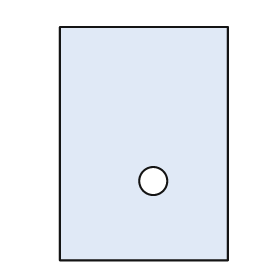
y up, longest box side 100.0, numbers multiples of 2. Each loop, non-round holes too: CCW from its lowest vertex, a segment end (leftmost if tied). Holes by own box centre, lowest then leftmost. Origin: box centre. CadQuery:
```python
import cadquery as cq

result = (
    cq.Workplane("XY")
    .moveTo(-36.0, -50.0)
    .lineTo(36.0, -50.0)
    .lineTo(36.0, 50.0)
    .lineTo(-36.0, 50.0)
    .close()
    .moveTo(4.0, -16.0)
    .circle(6.0)
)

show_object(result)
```